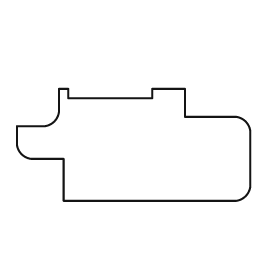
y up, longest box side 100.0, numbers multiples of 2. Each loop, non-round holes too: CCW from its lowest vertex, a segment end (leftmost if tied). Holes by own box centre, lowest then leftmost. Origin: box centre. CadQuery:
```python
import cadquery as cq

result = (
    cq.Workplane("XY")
    .moveTo(-30.0, -24.0)
    .lineTo(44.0, -24.0)
    .threePointArc((48.0, -22.0), (50.0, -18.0))
    .lineTo(50.0, 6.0)
    .threePointArc((48.0, 10.0), (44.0, 12.0))
    .lineTo(22.0, 12.0)
    .lineTo(22.0, 24.0)
    .lineTo(8.0, 24.0)
    .lineTo(8.0, 20.0)
    .lineTo(-28.0, 20.0)
    .lineTo(-28.0, 24.0)
    .lineTo(-32.0, 24.0)
    .lineTo(-32.0, 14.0)
    .threePointArc((-34.0, 10.0), (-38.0, 8.0))
    .lineTo(-50.0, 8.0)
    .lineTo(-50.0, 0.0)
    .threePointArc((-48.0, -4.0), (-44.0, -6.0))
    .lineTo(-30.0, -6.0)
    .close()
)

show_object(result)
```